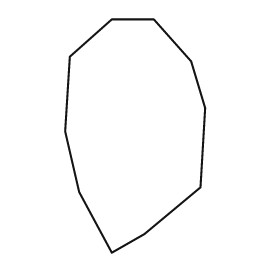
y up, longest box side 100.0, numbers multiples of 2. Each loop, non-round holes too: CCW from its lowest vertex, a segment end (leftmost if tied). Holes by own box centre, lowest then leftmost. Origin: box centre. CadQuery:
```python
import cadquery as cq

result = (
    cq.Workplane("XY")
    .moveTo(-10.0, -50.0)
    .lineTo(4.0, -42.0)
    .lineTo(28.0, -22.0)
    .lineTo(30.0, 12.0)
    .lineTo(24.0, 32.0)
    .lineTo(8.0, 50.0)
    .lineTo(-10.0, 50.0)
    .lineTo(-28.0, 34.0)
    .lineTo(-30.0, 2.0)
    .lineTo(-24.0, -24.0)
    .close()
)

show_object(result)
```